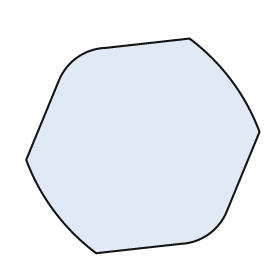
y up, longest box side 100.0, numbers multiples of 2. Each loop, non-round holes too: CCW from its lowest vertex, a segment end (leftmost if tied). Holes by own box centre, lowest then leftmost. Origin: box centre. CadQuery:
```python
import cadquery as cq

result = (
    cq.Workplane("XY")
    .moveTo(-20.0, -46.0)
    .lineTo(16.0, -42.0)
    .threePointArc((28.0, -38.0), (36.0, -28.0))
    .lineTo(50.0, 6.0)
    .threePointArc((38.0, 28.0), (20.0, 46.0))
    .lineTo(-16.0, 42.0)
    .threePointArc((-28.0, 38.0), (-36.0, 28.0))
    .lineTo(-50.0, -6.0)
    .threePointArc((-38.0, -28.0), (-20.0, -46.0))
    .close()
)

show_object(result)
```